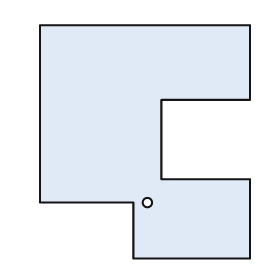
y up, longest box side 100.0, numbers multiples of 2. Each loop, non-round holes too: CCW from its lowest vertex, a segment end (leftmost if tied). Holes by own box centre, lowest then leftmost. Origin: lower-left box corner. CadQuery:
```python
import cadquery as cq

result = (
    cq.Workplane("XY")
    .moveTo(40.0, 0.0)
    .lineTo(90.0, 0.0)
    .lineTo(90.0, 34.0)
    .lineTo(52.0, 34.0)
    .lineTo(52.0, 68.0)
    .lineTo(90.0, 68.0)
    .lineTo(90.0, 100.0)
    .lineTo(0.0, 100.0)
    .lineTo(0.0, 24.0)
    .lineTo(40.0, 24.0)
    .close()
    .moveTo(46.0, 24.0)
    .circle(2.0)
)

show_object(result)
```